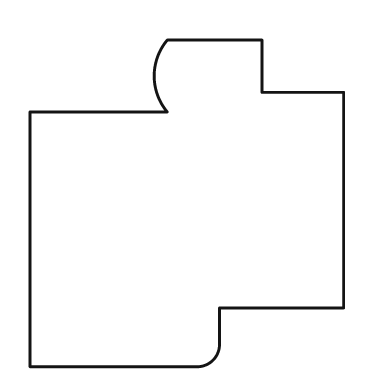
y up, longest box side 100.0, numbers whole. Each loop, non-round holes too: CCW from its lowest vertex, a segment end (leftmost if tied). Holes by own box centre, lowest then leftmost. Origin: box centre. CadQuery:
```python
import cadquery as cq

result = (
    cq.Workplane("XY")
    .moveTo(-48.0, -50.0)
    .lineTo(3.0, -50.0)
    .threePointArc((8.0, -48.0), (10.0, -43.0))
    .lineTo(10.0, -32.0)
    .lineTo(48.0, -32.0)
    .lineTo(48.0, 34.0)
    .lineTo(23.0, 34.0)
    .lineTo(23.0, 50.0)
    .lineTo(-6.0, 50.0)
    .threePointArc((-10.0, 39.0), (-6.0, 28.0))
    .lineTo(-48.0, 28.0)
    .close()
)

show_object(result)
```